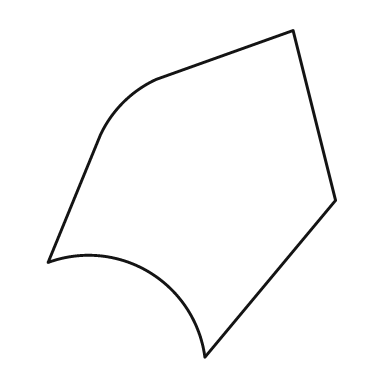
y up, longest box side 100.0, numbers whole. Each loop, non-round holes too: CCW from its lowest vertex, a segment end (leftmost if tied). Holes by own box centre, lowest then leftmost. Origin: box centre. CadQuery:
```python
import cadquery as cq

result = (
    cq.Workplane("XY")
    .moveTo(4.0, -50.0)
    .lineTo(44.0, -2.0)
    .lineTo(31.0, 50.0)
    .lineTo(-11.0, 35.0)
    .threePointArc((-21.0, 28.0), (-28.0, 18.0))
    .lineTo(-44.0, -21.0)
    .threePointArc((-13.0, -24.0), (4.0, -50.0))
    .close()
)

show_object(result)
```